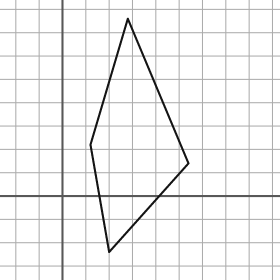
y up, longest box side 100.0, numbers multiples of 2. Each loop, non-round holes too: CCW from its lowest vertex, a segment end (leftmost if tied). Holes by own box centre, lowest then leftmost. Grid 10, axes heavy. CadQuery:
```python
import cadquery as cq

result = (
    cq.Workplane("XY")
    .moveTo(20.0, -24.0)
    .lineTo(54.0, 14.0)
    .lineTo(28.0, 76.0)
    .lineTo(12.0, 22.0)
    .close()
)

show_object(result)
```